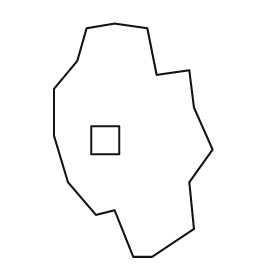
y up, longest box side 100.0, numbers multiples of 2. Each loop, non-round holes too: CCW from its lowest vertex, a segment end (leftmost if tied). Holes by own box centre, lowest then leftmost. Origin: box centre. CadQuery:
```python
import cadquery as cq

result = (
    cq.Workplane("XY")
    .moveTo(0.0, -50.0)
    .lineTo(8.0, -50.0)
    .lineTo(26.0, -38.0)
    .lineTo(24.0, -18.0)
    .lineTo(34.0, -4.0)
    .lineTo(26.0, 14.0)
    .lineTo(24.0, 30.0)
    .lineTo(10.0, 28.0)
    .lineTo(6.0, 48.0)
    .lineTo(-8.0, 50.0)
    .lineTo(-20.0, 48.0)
    .lineTo(-24.0, 34.0)
    .lineTo(-34.0, 22.0)
    .lineTo(-34.0, 2.0)
    .lineTo(-28.0, -18.0)
    .lineTo(-16.0, -32.0)
    .lineTo(-8.0, -30.0)
    .close()
    .moveTo(-18.0, -6.0)
    .lineTo(-6.0, -6.0)
    .lineTo(-6.0, 6.0)
    .lineTo(-18.0, 6.0)
    .close()
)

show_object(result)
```